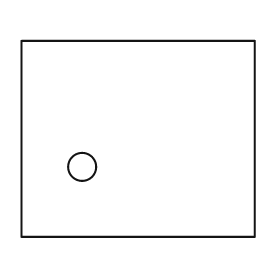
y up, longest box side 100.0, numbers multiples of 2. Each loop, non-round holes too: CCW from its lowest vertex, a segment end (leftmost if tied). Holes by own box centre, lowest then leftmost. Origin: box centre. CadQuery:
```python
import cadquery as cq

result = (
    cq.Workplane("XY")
    .moveTo(-50.0, -42.0)
    .lineTo(50.0, -42.0)
    .lineTo(50.0, 42.0)
    .lineTo(-50.0, 42.0)
    .close()
    .moveTo(-24.0, -12.0)
    .circle(6.0)
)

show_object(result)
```